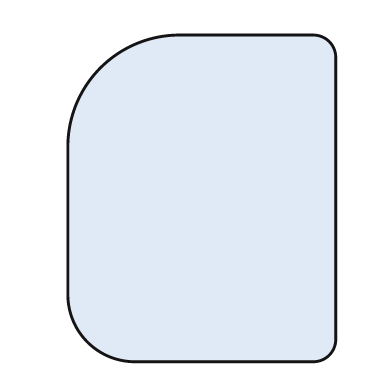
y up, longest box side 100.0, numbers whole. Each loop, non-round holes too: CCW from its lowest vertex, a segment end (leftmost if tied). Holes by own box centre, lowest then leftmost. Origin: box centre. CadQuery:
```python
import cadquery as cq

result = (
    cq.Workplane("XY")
    .moveTo(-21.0, -50.0)
    .lineTo(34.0, -50.0)
    .threePointArc((39.0, -48.0), (41.0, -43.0))
    .lineTo(41.0, 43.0)
    .threePointArc((39.0, 48.0), (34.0, 50.0))
    .lineTo(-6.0, 50.0)
    .threePointArc((-31.0, 40.0), (-41.0, 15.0))
    .lineTo(-41.0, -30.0)
    .threePointArc((-35.0, -44.0), (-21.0, -50.0))
    .close()
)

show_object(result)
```